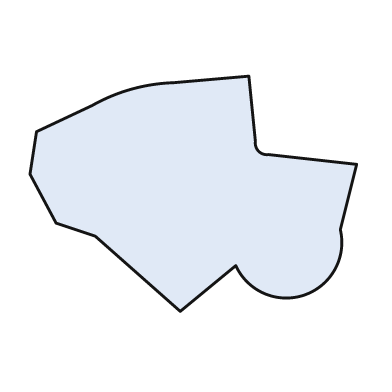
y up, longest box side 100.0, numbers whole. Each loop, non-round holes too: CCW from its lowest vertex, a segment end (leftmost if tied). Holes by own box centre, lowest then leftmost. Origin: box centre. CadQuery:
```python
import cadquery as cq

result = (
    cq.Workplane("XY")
    .moveTo(-4.0, -36.0)
    .lineTo(13.0, -22.0)
    .threePointArc((34.0, -31.0), (45.0, -11.0))
    .lineTo(50.0, 9.0)
    .lineTo(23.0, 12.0)
    .threePointArc((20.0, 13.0), (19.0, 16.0))
    .lineTo(17.0, 36.0)
    .lineTo(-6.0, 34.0)
    .threePointArc((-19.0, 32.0), (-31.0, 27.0))
    .lineTo(-48.0, 19.0)
    .lineTo(-50.0, 6.0)
    .lineTo(-42.0, -9.0)
    .lineTo(-30.0, -13.0)
    .close()
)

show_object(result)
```